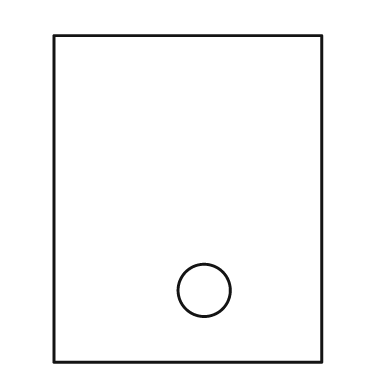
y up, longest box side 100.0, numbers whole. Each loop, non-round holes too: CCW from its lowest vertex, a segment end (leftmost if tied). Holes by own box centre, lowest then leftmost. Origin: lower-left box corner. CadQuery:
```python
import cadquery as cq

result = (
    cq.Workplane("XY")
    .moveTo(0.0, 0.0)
    .lineTo(82.0, 0.0)
    .lineTo(82.0, 100.0)
    .lineTo(0.0, 100.0)
    .close()
    .moveTo(46.0, 22.0)
    .circle(8.0)
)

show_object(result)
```